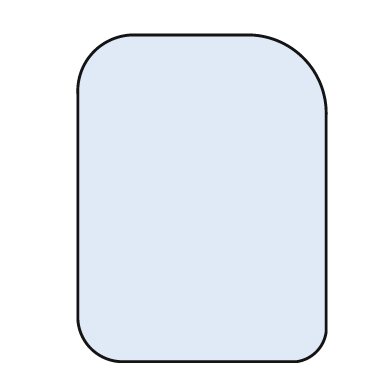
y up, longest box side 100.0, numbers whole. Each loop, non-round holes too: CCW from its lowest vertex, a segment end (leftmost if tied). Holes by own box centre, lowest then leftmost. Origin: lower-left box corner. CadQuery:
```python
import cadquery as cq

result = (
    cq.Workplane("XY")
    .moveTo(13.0, 0.0)
    .lineTo(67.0, 0.0)
    .threePointArc((73.0, 3.0), (76.0, 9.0))
    .lineTo(76.0, 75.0)
    .threePointArc((69.0, 93.0), (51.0, 100.0))
    .lineTo(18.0, 100.0)
    .threePointArc((5.0, 95.0), (0.0, 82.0))
    .lineTo(0.0, 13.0)
    .threePointArc((4.0, 4.0), (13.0, 0.0))
    .close()
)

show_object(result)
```